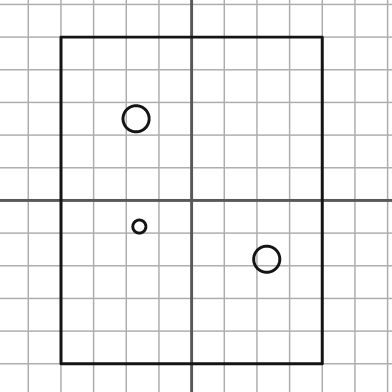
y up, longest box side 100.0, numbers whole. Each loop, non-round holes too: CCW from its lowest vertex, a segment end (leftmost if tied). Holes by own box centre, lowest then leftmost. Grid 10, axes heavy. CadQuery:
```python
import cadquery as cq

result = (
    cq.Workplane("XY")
    .moveTo(-40.0, -50.0)
    .lineTo(40.0, -50.0)
    .lineTo(40.0, 50.0)
    .lineTo(-40.0, 50.0)
    .close()
    .moveTo(23.0, -18.0)
    .circle(4.0)
    .moveTo(-16.0, -8.0)
    .circle(2.0)
    .moveTo(-17.0, 25.0)
    .circle(4.0)
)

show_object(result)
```